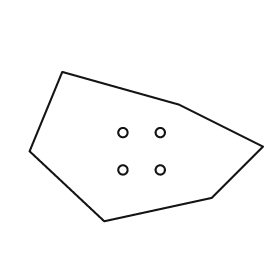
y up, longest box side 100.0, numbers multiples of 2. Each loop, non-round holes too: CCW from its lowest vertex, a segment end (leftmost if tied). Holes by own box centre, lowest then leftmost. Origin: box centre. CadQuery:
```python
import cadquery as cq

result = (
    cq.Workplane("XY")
    .moveTo(-18.0, -32.0)
    .lineTo(28.0, -22.0)
    .lineTo(50.0, 0.0)
    .lineTo(14.0, 18.0)
    .lineTo(-36.0, 32.0)
    .lineTo(-50.0, -2.0)
    .close()
    .moveTo(-10.0, -10.0)
    .circle(2.0)
    .moveTo(6.0, -10.0)
    .circle(2.0)
    .moveTo(-10.0, 6.0)
    .circle(2.0)
    .moveTo(6.0, 6.0)
    .circle(2.0)
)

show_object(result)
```